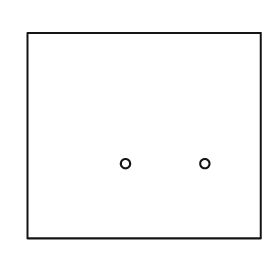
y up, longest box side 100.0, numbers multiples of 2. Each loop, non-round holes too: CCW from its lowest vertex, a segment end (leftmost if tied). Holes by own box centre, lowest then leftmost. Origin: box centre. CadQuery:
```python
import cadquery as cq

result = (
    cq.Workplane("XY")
    .moveTo(-50.0, -44.0)
    .lineTo(50.0, -44.0)
    .lineTo(50.0, 44.0)
    .lineTo(-50.0, 44.0)
    .close()
    .moveTo(-8.0, -12.0)
    .circle(2.0)
    .moveTo(26.0, -12.0)
    .circle(2.0)
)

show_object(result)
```